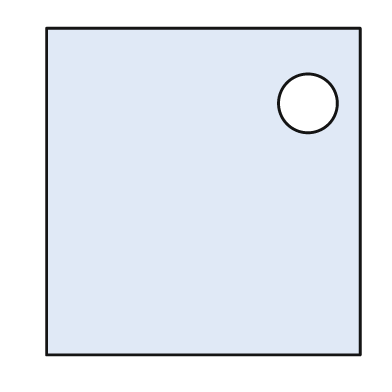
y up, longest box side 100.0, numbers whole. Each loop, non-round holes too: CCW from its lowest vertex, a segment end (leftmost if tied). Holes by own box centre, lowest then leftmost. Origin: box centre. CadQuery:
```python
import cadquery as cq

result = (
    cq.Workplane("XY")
    .moveTo(-48.0, -50.0)
    .lineTo(48.0, -50.0)
    .lineTo(48.0, 50.0)
    .lineTo(-48.0, 50.0)
    .close()
    .moveTo(32.0, 27.0)
    .circle(9.0)
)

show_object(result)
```